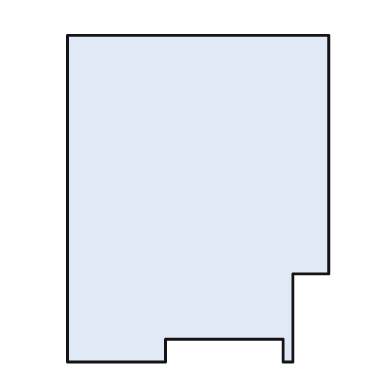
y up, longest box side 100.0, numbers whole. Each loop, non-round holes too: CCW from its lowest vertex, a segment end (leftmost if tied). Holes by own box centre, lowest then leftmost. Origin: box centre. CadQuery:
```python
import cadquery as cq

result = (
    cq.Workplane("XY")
    .moveTo(-40.0, -50.0)
    .lineTo(-10.0, -50.0)
    .lineTo(-10.0, -43.0)
    .lineTo(26.0, -43.0)
    .lineTo(26.0, -50.0)
    .lineTo(29.0, -50.0)
    .lineTo(29.0, -23.0)
    .lineTo(40.0, -23.0)
    .lineTo(40.0, 50.0)
    .lineTo(-40.0, 50.0)
    .close()
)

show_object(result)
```